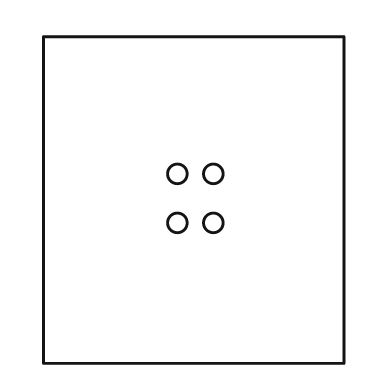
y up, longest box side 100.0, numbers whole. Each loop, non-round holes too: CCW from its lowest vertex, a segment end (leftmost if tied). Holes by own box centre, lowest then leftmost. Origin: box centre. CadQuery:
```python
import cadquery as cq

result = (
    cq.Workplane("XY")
    .moveTo(-46.0, -50.0)
    .lineTo(46.0, -50.0)
    .lineTo(46.0, 50.0)
    .lineTo(-46.0, 50.0)
    .close()
    .moveTo(-5.0, -7.0)
    .circle(3.0)
    .moveTo(6.0, -7.0)
    .circle(3.0)
    .moveTo(-5.0, 8.0)
    .circle(3.0)
    .moveTo(6.0, 8.0)
    .circle(3.0)
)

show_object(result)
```